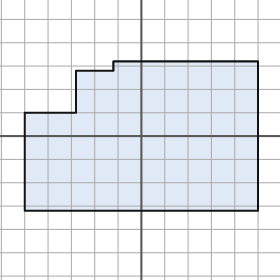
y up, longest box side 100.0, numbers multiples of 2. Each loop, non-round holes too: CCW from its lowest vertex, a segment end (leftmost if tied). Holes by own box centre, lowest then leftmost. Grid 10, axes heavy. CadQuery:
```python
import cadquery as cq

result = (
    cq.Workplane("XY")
    .moveTo(-50.0, -32.0)
    .lineTo(50.0, -32.0)
    .lineTo(50.0, 32.0)
    .lineTo(-12.0, 32.0)
    .lineTo(-12.0, 28.0)
    .lineTo(-28.0, 28.0)
    .lineTo(-28.0, 10.0)
    .lineTo(-50.0, 10.0)
    .close()
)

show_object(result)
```